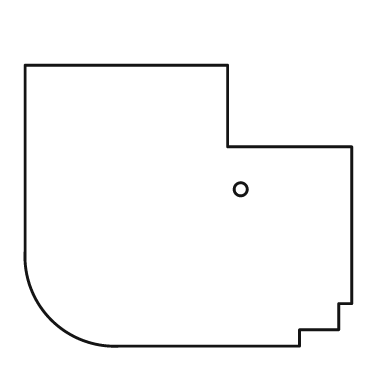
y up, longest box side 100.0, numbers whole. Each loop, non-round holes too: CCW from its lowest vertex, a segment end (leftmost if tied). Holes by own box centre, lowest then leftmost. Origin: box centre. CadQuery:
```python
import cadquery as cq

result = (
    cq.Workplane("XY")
    .moveTo(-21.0, -43.0)
    .lineTo(34.0, -43.0)
    .lineTo(34.0, -38.0)
    .lineTo(46.0, -38.0)
    .lineTo(46.0, -30.0)
    .lineTo(50.0, -30.0)
    .lineTo(50.0, 18.0)
    .lineTo(12.0, 18.0)
    .lineTo(12.0, 43.0)
    .lineTo(-50.0, 43.0)
    .lineTo(-50.0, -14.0)
    .threePointArc((-42.0, -35.0), (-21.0, -43.0))
    .close()
    .moveTo(16.0, 5.0)
    .circle(2.0)
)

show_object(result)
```